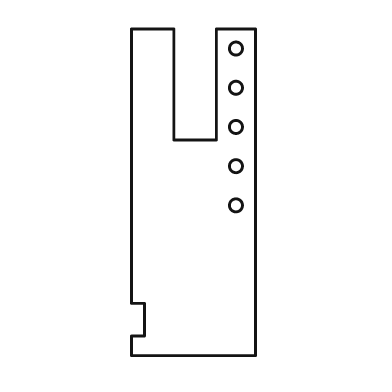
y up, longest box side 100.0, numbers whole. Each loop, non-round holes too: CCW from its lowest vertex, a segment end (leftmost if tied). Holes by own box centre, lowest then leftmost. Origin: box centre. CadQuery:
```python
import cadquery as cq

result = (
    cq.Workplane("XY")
    .moveTo(-19.0, -50.0)
    .lineTo(19.0, -50.0)
    .lineTo(19.0, 50.0)
    .lineTo(7.0, 50.0)
    .lineTo(7.0, 16.0)
    .lineTo(-6.0, 16.0)
    .lineTo(-6.0, 50.0)
    .lineTo(-19.0, 50.0)
    .lineTo(-19.0, -34.0)
    .lineTo(-15.0, -34.0)
    .lineTo(-15.0, -44.0)
    .lineTo(-19.0, -44.0)
    .close()
    .moveTo(13.0, -4.0)
    .circle(2.0)
    .moveTo(13.0, 8.0)
    .circle(2.0)
    .moveTo(13.0, 20.0)
    .circle(2.0)
    .moveTo(13.0, 32.0)
    .circle(2.0)
    .moveTo(13.0, 44.0)
    .circle(2.0)
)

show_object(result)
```